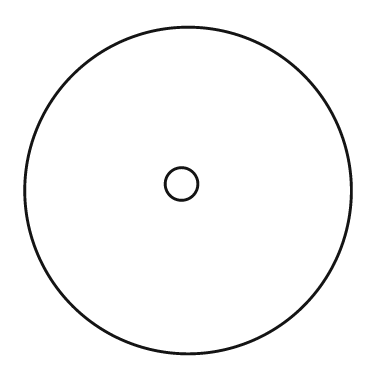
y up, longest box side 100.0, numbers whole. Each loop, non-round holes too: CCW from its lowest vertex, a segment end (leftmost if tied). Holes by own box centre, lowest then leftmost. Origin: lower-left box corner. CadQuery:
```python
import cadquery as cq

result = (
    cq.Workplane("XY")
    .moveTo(50.0, 50.0)
    .circle(50.0)
    .moveTo(48.0, 52.0)
    .circle(5.0)
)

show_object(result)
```